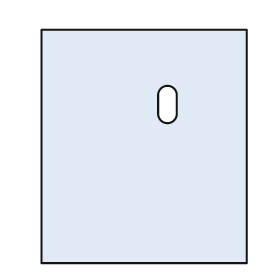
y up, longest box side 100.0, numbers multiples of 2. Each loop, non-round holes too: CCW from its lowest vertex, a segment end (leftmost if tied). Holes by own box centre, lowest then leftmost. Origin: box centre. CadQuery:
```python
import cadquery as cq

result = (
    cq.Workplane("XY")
    .moveTo(-44.0, -50.0)
    .lineTo(44.0, -50.0)
    .lineTo(44.0, 50.0)
    .lineTo(-44.0, 50.0)
    .close()
    .moveTo(6.0, 14.0)
    .threePointArc((10.0, 10.0), (14.0, 14.0))
    .lineTo(14.0, 22.0)
    .threePointArc((10.0, 26.0), (6.0, 22.0))
    .close()
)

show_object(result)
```